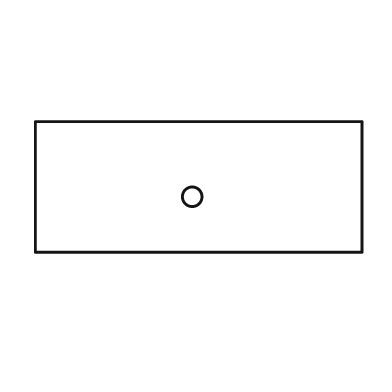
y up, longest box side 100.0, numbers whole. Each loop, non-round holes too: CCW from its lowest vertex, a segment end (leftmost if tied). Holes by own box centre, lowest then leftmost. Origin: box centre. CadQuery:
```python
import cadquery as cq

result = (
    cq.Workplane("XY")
    .moveTo(-50.0, -20.0)
    .lineTo(50.0, -20.0)
    .lineTo(50.0, 20.0)
    .lineTo(-50.0, 20.0)
    .close()
    .moveTo(-2.0, -3.0)
    .circle(3.0)
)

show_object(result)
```